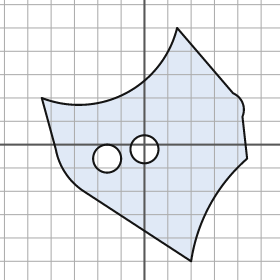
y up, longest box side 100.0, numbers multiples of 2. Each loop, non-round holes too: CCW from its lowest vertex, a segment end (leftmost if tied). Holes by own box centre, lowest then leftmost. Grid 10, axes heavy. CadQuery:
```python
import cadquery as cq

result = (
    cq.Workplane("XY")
    .moveTo(20.0, -50.0)
    .threePointArc((28.0, -26.0), (44.0, -6.0))
    .lineTo(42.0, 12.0)
    .threePointArc((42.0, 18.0), (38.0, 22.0))
    .lineTo(14.0, 50.0)
    .threePointArc((-8.0, 22.0), (-44.0, 20.0))
    .lineTo(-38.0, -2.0)
    .threePointArc((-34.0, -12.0), (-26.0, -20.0))
    .close()
    .moveTo(-16.0, -6.0)
    .circle(6.0)
    .moveTo(0.0, -2.0)
    .circle(6.0)
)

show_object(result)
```